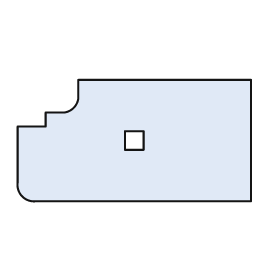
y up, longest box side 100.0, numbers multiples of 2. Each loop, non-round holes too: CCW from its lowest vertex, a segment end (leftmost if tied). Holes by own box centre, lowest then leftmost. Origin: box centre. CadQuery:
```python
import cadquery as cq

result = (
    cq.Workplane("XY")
    .moveTo(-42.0, -26.0)
    .lineTo(50.0, -26.0)
    .lineTo(50.0, 26.0)
    .lineTo(-24.0, 26.0)
    .lineTo(-24.0, 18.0)
    .threePointArc((-26.0, 14.0), (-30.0, 12.0))
    .lineTo(-38.0, 12.0)
    .lineTo(-38.0, 6.0)
    .lineTo(-50.0, 6.0)
    .lineTo(-50.0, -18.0)
    .threePointArc((-48.0, -24.0), (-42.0, -26.0))
    .close()
    .moveTo(-4.0, -4.0)
    .lineTo(4.0, -4.0)
    .lineTo(4.0, 4.0)
    .lineTo(-4.0, 4.0)
    .close()
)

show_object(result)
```